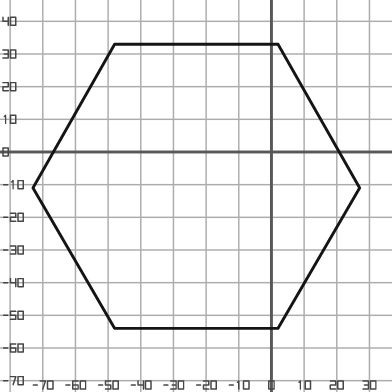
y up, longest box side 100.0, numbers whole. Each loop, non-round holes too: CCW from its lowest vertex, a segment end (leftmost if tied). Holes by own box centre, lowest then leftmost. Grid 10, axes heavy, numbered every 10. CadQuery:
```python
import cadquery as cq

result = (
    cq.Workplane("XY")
    .moveTo(-48.0, -54.0)
    .lineTo(2.0, -54.0)
    .lineTo(27.0, -11.0)
    .lineTo(2.0, 33.0)
    .lineTo(-48.0, 33.0)
    .lineTo(-73.0, -11.0)
    .close()
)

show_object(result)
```